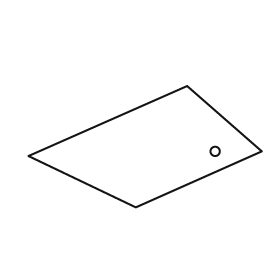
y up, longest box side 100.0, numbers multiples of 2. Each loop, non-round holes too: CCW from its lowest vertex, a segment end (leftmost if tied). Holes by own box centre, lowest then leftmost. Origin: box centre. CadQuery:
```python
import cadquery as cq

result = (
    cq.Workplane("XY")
    .moveTo(-4.0, -26.0)
    .lineTo(50.0, -2.0)
    .lineTo(18.0, 26.0)
    .lineTo(-50.0, -4.0)
    .close()
    .moveTo(30.0, -2.0)
    .circle(2.0)
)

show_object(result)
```